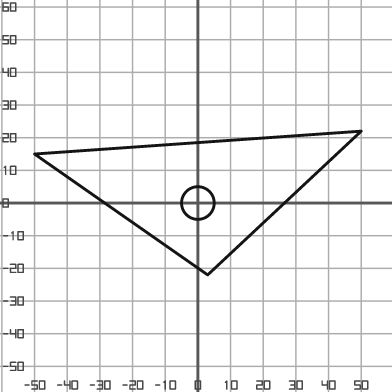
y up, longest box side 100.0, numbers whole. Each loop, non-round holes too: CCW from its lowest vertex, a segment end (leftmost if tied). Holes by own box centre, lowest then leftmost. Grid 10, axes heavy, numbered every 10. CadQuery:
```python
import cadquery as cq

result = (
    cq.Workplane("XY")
    .moveTo(3.0, -22.0)
    .lineTo(50.0, 22.0)
    .lineTo(-50.0, 15.0)
    .close()
    .moveTo(0.0, 0.0)
    .circle(5.0)
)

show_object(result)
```